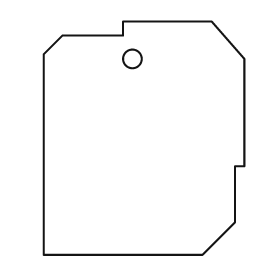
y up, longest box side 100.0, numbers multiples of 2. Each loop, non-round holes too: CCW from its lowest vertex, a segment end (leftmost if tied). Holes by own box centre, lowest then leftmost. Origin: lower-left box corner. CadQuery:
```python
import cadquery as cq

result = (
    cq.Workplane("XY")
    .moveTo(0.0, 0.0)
    .lineTo(68.0, 0.0)
    .lineTo(82.0, 14.0)
    .lineTo(82.0, 38.0)
    .lineTo(86.0, 38.0)
    .lineTo(86.0, 84.0)
    .lineTo(72.0, 100.0)
    .lineTo(34.0, 100.0)
    .lineTo(34.0, 94.0)
    .lineTo(8.0, 94.0)
    .lineTo(0.0, 86.0)
    .close()
    .moveTo(38.0, 84.0)
    .circle(4.0)
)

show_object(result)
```